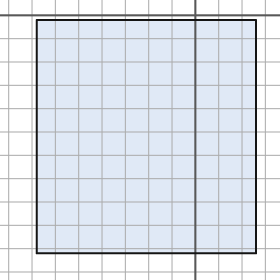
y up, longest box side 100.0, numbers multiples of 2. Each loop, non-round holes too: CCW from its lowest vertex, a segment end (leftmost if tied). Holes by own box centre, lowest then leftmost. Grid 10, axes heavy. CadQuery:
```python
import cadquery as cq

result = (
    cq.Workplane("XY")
    .moveTo(-68.0, -102.0)
    .lineTo(26.0, -102.0)
    .lineTo(26.0, -2.0)
    .lineTo(-68.0, -2.0)
    .close()
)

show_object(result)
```